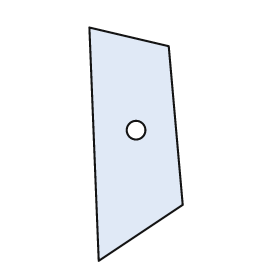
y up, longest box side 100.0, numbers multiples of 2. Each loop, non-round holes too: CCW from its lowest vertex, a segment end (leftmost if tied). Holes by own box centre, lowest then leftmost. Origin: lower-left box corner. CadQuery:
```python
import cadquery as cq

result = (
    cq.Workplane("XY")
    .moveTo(4.0, 0.0)
    .lineTo(40.0, 24.0)
    .lineTo(34.0, 92.0)
    .lineTo(0.0, 100.0)
    .close()
    .moveTo(20.0, 56.0)
    .circle(4.0)
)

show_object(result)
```